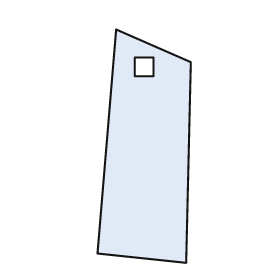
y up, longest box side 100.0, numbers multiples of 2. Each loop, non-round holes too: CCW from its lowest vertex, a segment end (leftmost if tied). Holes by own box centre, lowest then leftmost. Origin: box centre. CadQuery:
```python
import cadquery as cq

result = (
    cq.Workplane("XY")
    .moveTo(18.0, -50.0)
    .lineTo(20.0, 36.0)
    .lineTo(-12.0, 50.0)
    .lineTo(-20.0, -46.0)
    .close()
    .moveTo(-4.0, 30.0)
    .lineTo(4.0, 30.0)
    .lineTo(4.0, 38.0)
    .lineTo(-4.0, 38.0)
    .close()
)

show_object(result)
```